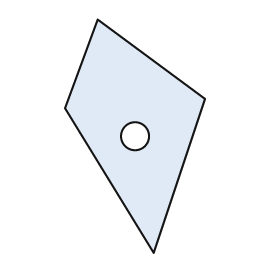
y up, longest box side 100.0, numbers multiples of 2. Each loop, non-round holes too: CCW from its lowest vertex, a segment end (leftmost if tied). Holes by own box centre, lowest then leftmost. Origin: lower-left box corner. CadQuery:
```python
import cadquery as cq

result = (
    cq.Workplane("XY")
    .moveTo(38.0, 0.0)
    .lineTo(60.0, 66.0)
    .lineTo(14.0, 100.0)
    .lineTo(0.0, 62.0)
    .close()
    .moveTo(30.0, 50.0)
    .circle(6.0)
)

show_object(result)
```